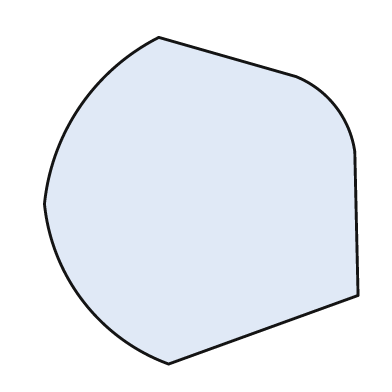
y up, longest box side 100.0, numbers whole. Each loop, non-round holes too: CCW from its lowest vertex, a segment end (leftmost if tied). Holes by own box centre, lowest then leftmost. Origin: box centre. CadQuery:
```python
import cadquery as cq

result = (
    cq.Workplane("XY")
    .moveTo(-10.0, -50.0)
    .lineTo(48.0, -29.0)
    .lineTo(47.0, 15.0)
    .threePointArc((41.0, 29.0), (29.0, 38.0))
    .lineTo(-13.0, 50.0)
    .threePointArc((-37.0, 29.0), (-48.0, -1.0))
    .threePointArc((-36.0, -31.0), (-10.0, -50.0))
    .close()
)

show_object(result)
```